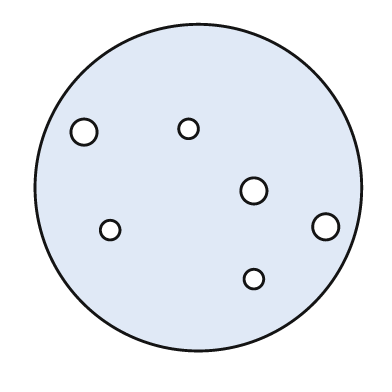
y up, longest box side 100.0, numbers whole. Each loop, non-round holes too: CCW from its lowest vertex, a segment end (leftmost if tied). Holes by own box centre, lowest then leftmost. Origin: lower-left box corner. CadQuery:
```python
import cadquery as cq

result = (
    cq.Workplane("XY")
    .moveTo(50.0, 50.0)
    .circle(50.0)
    .moveTo(67.0, 22.0)
    .circle(3.0)
    .moveTo(23.0, 37.0)
    .circle(3.0)
    .moveTo(89.0, 38.0)
    .circle(4.0)
    .moveTo(67.0, 49.0)
    .circle(4.0)
    .moveTo(15.0, 67.0)
    .circle(4.0)
    .moveTo(47.0, 68.0)
    .circle(3.0)
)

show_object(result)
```